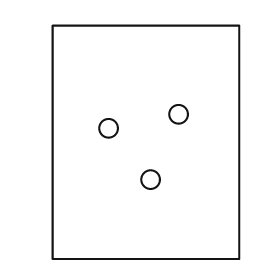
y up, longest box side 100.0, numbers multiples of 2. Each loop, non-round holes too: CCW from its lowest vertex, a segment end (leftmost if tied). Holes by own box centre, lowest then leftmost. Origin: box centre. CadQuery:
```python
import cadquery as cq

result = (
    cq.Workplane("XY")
    .moveTo(-40.0, -50.0)
    .lineTo(40.0, -50.0)
    .lineTo(40.0, 50.0)
    .lineTo(-40.0, 50.0)
    .close()
    .moveTo(2.0, -16.0)
    .circle(4.0)
    .moveTo(-16.0, 6.0)
    .circle(4.0)
    .moveTo(14.0, 12.0)
    .circle(4.0)
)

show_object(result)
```